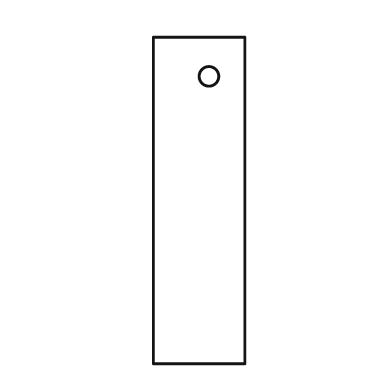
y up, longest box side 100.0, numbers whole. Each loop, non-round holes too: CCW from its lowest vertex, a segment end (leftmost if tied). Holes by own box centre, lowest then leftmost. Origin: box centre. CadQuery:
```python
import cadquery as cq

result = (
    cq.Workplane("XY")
    .moveTo(-14.0, -50.0)
    .lineTo(14.0, -50.0)
    .lineTo(14.0, 50.0)
    .lineTo(-14.0, 50.0)
    .close()
    .moveTo(3.0, 38.0)
    .circle(3.0)
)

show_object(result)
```